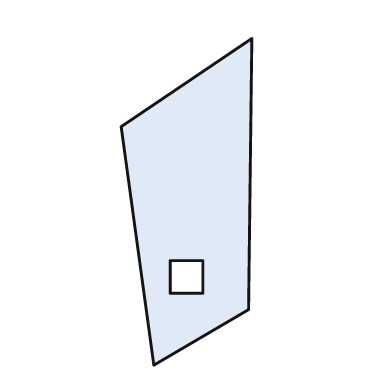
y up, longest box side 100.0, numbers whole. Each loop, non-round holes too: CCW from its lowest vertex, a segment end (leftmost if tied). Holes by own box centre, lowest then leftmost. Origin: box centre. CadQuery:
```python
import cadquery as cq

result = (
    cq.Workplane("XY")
    .moveTo(-10.0, -50.0)
    .lineTo(19.0, -33.0)
    .lineTo(20.0, 50.0)
    .lineTo(-20.0, 23.0)
    .close()
    .moveTo(-5.0, -28.0)
    .lineTo(5.0, -28.0)
    .lineTo(5.0, -18.0)
    .lineTo(-5.0, -18.0)
    .close()
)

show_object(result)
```